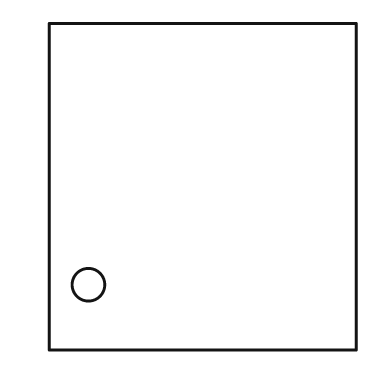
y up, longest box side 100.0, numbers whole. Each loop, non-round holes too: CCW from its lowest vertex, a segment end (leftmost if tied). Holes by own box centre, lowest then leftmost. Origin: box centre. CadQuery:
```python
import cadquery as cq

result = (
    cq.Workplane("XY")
    .moveTo(-47.0, -50.0)
    .lineTo(47.0, -50.0)
    .lineTo(47.0, 50.0)
    .lineTo(-47.0, 50.0)
    .close()
    .moveTo(-35.0, -30.0)
    .circle(5.0)
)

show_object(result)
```